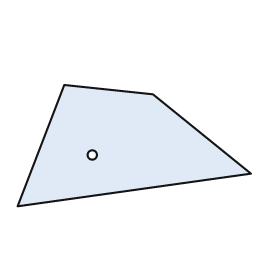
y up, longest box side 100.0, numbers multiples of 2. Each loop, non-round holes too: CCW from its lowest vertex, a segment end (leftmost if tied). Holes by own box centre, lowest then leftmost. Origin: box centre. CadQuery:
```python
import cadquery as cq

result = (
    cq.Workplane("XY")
    .moveTo(-50.0, -26.0)
    .lineTo(50.0, -12.0)
    .lineTo(8.0, 22.0)
    .lineTo(-30.0, 26.0)
    .close()
    .moveTo(-18.0, -4.0)
    .circle(2.0)
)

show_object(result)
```